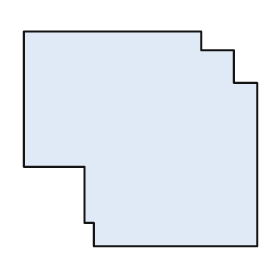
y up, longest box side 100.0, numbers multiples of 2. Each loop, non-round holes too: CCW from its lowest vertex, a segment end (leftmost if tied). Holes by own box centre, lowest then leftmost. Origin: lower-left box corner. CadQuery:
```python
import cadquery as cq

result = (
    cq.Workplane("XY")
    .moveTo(30.0, 0.0)
    .lineTo(100.0, 0.0)
    .lineTo(100.0, 70.0)
    .lineTo(90.0, 70.0)
    .lineTo(90.0, 84.0)
    .lineTo(76.0, 84.0)
    .lineTo(76.0, 92.0)
    .lineTo(0.0, 92.0)
    .lineTo(0.0, 34.0)
    .lineTo(26.0, 34.0)
    .lineTo(26.0, 10.0)
    .lineTo(30.0, 10.0)
    .close()
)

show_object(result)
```